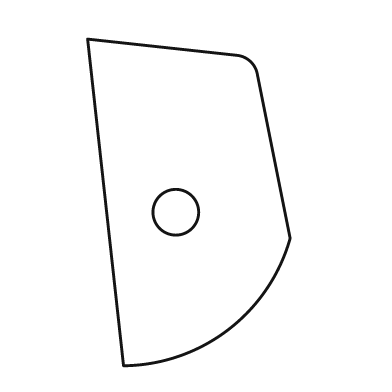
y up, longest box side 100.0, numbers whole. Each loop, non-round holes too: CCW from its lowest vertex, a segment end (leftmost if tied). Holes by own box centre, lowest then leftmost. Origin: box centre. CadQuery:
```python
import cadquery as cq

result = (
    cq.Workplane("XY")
    .moveTo(-20.0, -50.0)
    .threePointArc((12.0, -39.0), (31.0, -11.0))
    .lineTo(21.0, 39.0)
    .threePointArc((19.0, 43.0), (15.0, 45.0))
    .lineTo(-31.0, 50.0)
    .close()
    .moveTo(-4.0, -3.0)
    .circle(7.0)
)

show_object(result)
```